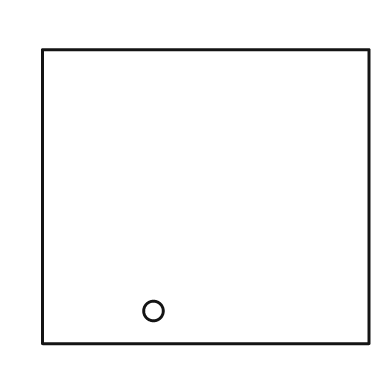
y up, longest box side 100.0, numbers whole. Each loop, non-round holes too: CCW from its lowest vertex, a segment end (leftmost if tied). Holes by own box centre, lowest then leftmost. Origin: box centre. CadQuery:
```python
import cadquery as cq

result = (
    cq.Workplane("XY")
    .moveTo(-50.0, -45.0)
    .lineTo(50.0, -45.0)
    .lineTo(50.0, 45.0)
    .lineTo(-50.0, 45.0)
    .close()
    .moveTo(-16.0, -35.0)
    .circle(3.0)
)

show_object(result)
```